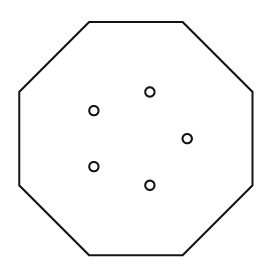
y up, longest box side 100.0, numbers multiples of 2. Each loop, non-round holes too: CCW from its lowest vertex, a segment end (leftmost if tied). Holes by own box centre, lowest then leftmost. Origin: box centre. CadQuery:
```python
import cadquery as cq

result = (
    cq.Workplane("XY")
    .moveTo(-20.0, -50.0)
    .lineTo(20.0, -50.0)
    .lineTo(50.0, -20.0)
    .lineTo(50.0, 20.0)
    .lineTo(20.0, 50.0)
    .lineTo(-20.0, 50.0)
    .lineTo(-50.0, 20.0)
    .lineTo(-50.0, -20.0)
    .close()
    .moveTo(6.0, -20.0)
    .circle(2.0)
    .moveTo(-18.0, -12.0)
    .circle(2.0)
    .moveTo(22.0, 0.0)
    .circle(2.0)
    .moveTo(-18.0, 12.0)
    .circle(2.0)
    .moveTo(6.0, 20.0)
    .circle(2.0)
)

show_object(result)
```